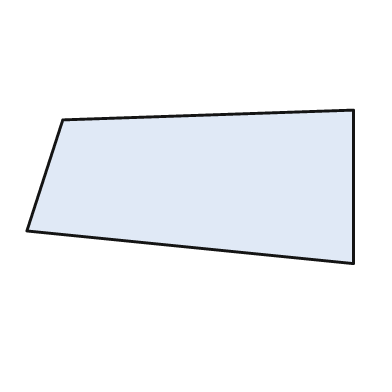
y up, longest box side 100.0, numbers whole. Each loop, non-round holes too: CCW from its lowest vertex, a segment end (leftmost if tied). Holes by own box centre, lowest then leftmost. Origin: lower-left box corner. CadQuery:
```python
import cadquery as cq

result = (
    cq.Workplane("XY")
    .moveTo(100.0, 0.0)
    .lineTo(100.0, 47.0)
    .lineTo(11.0, 44.0)
    .lineTo(0.0, 10.0)
    .close()
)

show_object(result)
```